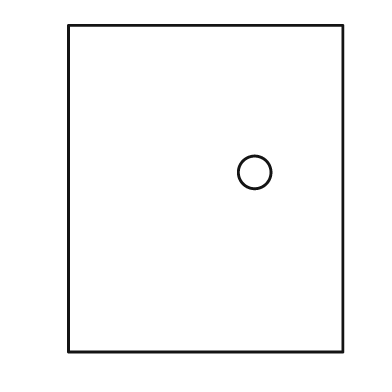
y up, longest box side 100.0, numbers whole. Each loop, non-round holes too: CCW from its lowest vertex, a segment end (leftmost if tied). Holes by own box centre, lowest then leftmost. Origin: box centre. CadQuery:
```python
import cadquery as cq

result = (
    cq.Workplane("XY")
    .moveTo(-42.0, -50.0)
    .lineTo(42.0, -50.0)
    .lineTo(42.0, 50.0)
    .lineTo(-42.0, 50.0)
    .close()
    .moveTo(15.0, 5.0)
    .circle(5.0)
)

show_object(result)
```